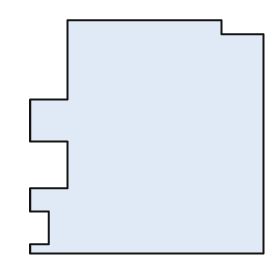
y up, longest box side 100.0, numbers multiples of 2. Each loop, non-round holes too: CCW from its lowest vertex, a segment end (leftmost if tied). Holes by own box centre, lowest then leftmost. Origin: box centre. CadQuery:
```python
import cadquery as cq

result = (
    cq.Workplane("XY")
    .moveTo(-50.0, -50.0)
    .lineTo(50.0, -50.0)
    .lineTo(50.0, 44.0)
    .lineTo(32.0, 44.0)
    .lineTo(32.0, 50.0)
    .lineTo(-34.0, 50.0)
    .lineTo(-34.0, 16.0)
    .lineTo(-50.0, 16.0)
    .lineTo(-50.0, -2.0)
    .lineTo(-34.0, -2.0)
    .lineTo(-34.0, -22.0)
    .lineTo(-50.0, -22.0)
    .lineTo(-50.0, -32.0)
    .lineTo(-42.0, -32.0)
    .lineTo(-42.0, -46.0)
    .lineTo(-50.0, -46.0)
    .close()
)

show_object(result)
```